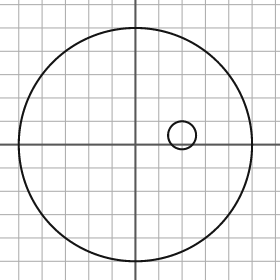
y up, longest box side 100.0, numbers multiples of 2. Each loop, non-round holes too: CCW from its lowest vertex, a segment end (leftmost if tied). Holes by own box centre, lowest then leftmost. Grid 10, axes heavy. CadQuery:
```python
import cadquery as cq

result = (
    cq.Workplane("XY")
    .moveTo(0.0, 0.0)
    .circle(50.0)
    .moveTo(20.0, 4.0)
    .circle(6.0)
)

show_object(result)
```